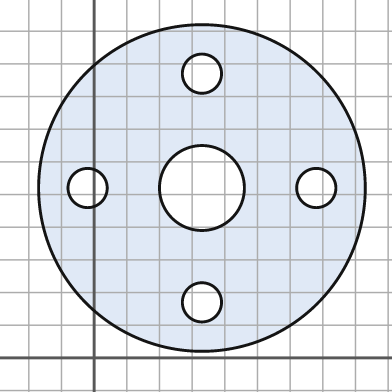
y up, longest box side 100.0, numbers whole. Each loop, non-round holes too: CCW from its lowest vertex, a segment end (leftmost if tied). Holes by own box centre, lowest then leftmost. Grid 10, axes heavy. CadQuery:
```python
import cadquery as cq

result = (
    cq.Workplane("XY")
    .moveTo(33.0, 52.0)
    .circle(50.0)
    .moveTo(33.0, 17.0)
    .circle(6.0)
    .moveTo(-2.0, 52.0)
    .circle(6.0)
    .moveTo(33.0, 52.0)
    .circle(13.0)
    .moveTo(68.0, 52.0)
    .circle(6.0)
    .moveTo(33.0, 87.0)
    .circle(6.0)
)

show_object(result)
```